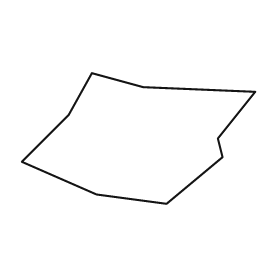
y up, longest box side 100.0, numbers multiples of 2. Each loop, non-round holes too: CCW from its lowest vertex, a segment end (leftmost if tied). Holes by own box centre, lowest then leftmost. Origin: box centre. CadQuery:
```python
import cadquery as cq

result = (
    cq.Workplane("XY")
    .moveTo(12.0, -28.0)
    .lineTo(36.0, -8.0)
    .lineTo(34.0, 0.0)
    .lineTo(50.0, 20.0)
    .lineTo(2.0, 22.0)
    .lineTo(-20.0, 28.0)
    .lineTo(-30.0, 10.0)
    .lineTo(-50.0, -10.0)
    .lineTo(-18.0, -24.0)
    .close()
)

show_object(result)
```